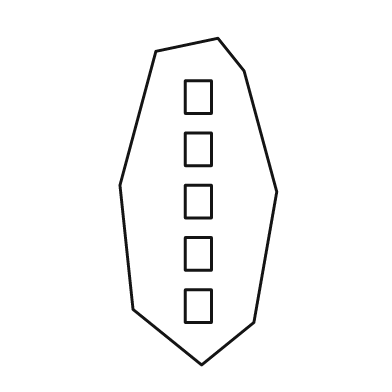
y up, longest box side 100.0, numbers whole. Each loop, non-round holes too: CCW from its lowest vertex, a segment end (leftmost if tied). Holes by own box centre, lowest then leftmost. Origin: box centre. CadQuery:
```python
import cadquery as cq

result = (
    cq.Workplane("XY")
    .moveTo(1.0, -50.0)
    .lineTo(17.0, -37.0)
    .lineTo(24.0, 3.0)
    .lineTo(14.0, 40.0)
    .lineTo(6.0, 50.0)
    .lineTo(-13.0, 46.0)
    .lineTo(-24.0, 5.0)
    .lineTo(-20.0, -33.0)
    .close()
    .moveTo(-4.0, -37.0)
    .lineTo(4.0, -37.0)
    .lineTo(4.0, -27.0)
    .lineTo(-4.0, -27.0)
    .close()
    .moveTo(-4.0, -21.0)
    .lineTo(4.0, -21.0)
    .lineTo(4.0, -11.0)
    .lineTo(-4.0, -11.0)
    .close()
    .moveTo(-4.0, -5.0)
    .lineTo(4.0, -5.0)
    .lineTo(4.0, 5.0)
    .lineTo(-4.0, 5.0)
    .close()
    .moveTo(-4.0, 11.0)
    .lineTo(4.0, 11.0)
    .lineTo(4.0, 21.0)
    .lineTo(-4.0, 21.0)
    .close()
    .moveTo(-4.0, 27.0)
    .lineTo(4.0, 27.0)
    .lineTo(4.0, 37.0)
    .lineTo(-4.0, 37.0)
    .close()
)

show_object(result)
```